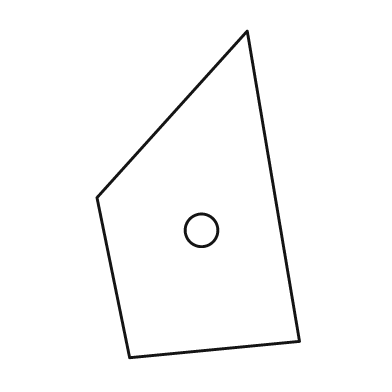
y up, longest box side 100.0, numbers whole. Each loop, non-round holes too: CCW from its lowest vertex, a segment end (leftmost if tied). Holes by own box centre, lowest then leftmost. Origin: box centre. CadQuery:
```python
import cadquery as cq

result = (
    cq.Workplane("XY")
    .moveTo(-21.0, -50.0)
    .lineTo(31.0, -45.0)
    .lineTo(15.0, 50.0)
    .lineTo(-31.0, -1.0)
    .close()
    .moveTo(1.0, -11.0)
    .circle(5.0)
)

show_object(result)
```